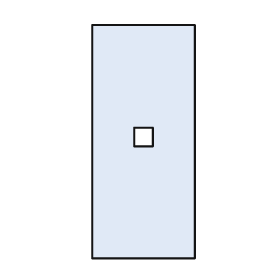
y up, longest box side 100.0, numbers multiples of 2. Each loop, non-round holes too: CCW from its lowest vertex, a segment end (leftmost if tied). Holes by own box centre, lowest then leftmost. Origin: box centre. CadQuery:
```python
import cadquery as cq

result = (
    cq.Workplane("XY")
    .moveTo(-22.0, -50.0)
    .lineTo(22.0, -50.0)
    .lineTo(22.0, 50.0)
    .lineTo(-22.0, 50.0)
    .close()
    .moveTo(-4.0, -2.0)
    .lineTo(4.0, -2.0)
    .lineTo(4.0, 6.0)
    .lineTo(-4.0, 6.0)
    .close()
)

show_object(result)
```